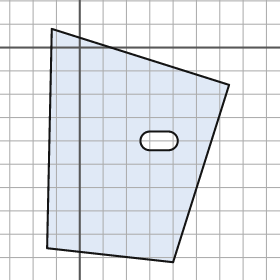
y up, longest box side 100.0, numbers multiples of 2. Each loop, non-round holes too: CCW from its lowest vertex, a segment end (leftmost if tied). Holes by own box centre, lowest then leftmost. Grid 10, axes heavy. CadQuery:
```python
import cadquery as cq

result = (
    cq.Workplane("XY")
    .moveTo(40.0, -92.0)
    .lineTo(64.0, -16.0)
    .lineTo(-12.0, 8.0)
    .lineTo(-14.0, -86.0)
    .close()
    .moveTo(30.0, -44.0)
    .lineTo(38.0, -44.0)
    .threePointArc((42.0, -40.0), (38.0, -36.0))
    .lineTo(30.0, -36.0)
    .threePointArc((26.0, -40.0), (30.0, -44.0))
    .close()
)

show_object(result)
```